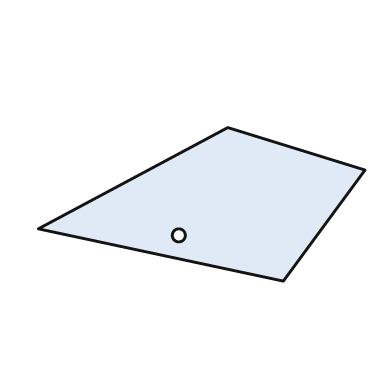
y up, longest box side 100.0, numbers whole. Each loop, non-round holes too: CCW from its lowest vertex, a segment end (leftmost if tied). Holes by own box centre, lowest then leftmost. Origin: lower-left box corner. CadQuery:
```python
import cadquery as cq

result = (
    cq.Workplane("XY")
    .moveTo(75.0, 0.0)
    .lineTo(100.0, 34.0)
    .lineTo(58.0, 47.0)
    .lineTo(0.0, 16.0)
    .close()
    .moveTo(43.0, 14.0)
    .circle(2.0)
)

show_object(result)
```